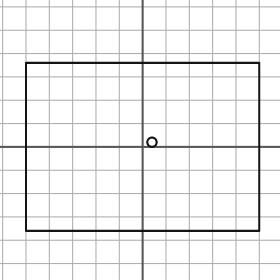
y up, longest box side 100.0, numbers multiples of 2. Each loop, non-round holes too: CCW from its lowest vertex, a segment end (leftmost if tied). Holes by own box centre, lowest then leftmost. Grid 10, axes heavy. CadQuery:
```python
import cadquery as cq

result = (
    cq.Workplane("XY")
    .moveTo(-50.0, -36.0)
    .lineTo(50.0, -36.0)
    .lineTo(50.0, 36.0)
    .lineTo(-50.0, 36.0)
    .close()
    .moveTo(4.0, 2.0)
    .circle(2.0)
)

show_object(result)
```